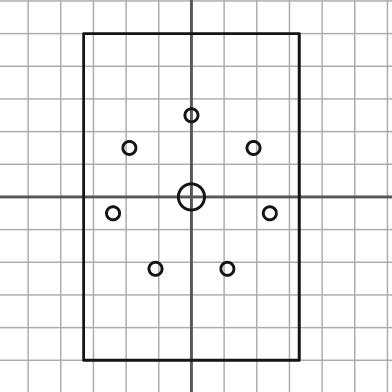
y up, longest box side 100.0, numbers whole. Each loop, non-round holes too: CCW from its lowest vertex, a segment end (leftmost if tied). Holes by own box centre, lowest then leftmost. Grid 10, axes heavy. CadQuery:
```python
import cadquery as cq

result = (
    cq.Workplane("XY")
    .moveTo(-33.0, -50.0)
    .lineTo(33.0, -50.0)
    .lineTo(33.0, 50.0)
    .lineTo(-33.0, 50.0)
    .close()
    .moveTo(-11.0, -22.0)
    .circle(2.0)
    .moveTo(11.0, -22.0)
    .circle(2.0)
    .moveTo(-24.0, -5.0)
    .circle(2.0)
    .moveTo(24.0, -5.0)
    .circle(2.0)
    .moveTo(0.0, 0.0)
    .circle(4.0)
    .moveTo(-19.0, 15.0)
    .circle(2.0)
    .moveTo(19.0, 15.0)
    .circle(2.0)
    .moveTo(0.0, 25.0)
    .circle(2.0)
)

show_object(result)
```